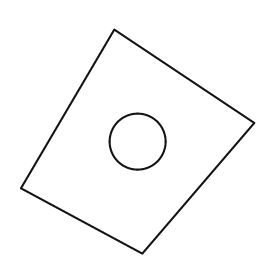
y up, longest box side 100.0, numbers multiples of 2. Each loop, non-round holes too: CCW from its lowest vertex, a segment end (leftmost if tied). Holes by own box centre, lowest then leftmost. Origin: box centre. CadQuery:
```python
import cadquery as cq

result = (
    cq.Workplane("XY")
    .moveTo(2.0, -48.0)
    .lineTo(50.0, 8.0)
    .lineTo(-10.0, 48.0)
    .lineTo(-50.0, -20.0)
    .close()
    .moveTo(0.0, 0.0)
    .circle(12.0)
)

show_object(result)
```